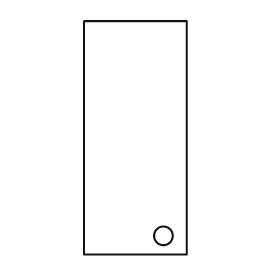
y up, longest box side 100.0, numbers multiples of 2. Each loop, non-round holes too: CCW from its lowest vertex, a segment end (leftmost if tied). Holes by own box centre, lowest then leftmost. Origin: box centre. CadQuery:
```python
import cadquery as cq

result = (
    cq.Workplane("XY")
    .moveTo(-22.0, -50.0)
    .lineTo(22.0, -50.0)
    .lineTo(22.0, 50.0)
    .lineTo(-22.0, 50.0)
    .close()
    .moveTo(12.0, -42.0)
    .circle(4.0)
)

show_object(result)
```